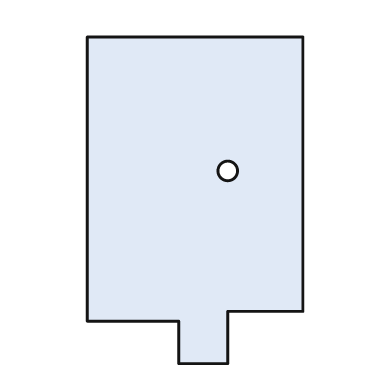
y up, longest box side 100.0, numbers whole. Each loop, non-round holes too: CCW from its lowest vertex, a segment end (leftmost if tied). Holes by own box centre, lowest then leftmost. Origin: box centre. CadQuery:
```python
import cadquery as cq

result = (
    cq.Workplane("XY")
    .moveTo(-5.0, -50.0)
    .lineTo(10.0, -50.0)
    .lineTo(10.0, -34.0)
    .lineTo(33.0, -34.0)
    .lineTo(33.0, 50.0)
    .lineTo(-33.0, 50.0)
    .lineTo(-33.0, -37.0)
    .lineTo(-5.0, -37.0)
    .close()
    .moveTo(10.0, 9.0)
    .circle(3.0)
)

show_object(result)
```